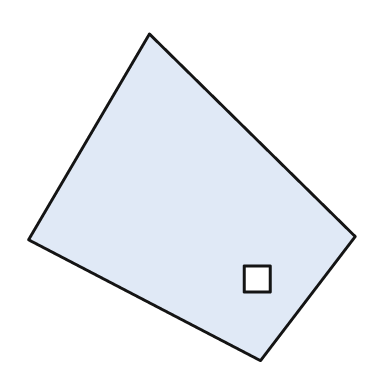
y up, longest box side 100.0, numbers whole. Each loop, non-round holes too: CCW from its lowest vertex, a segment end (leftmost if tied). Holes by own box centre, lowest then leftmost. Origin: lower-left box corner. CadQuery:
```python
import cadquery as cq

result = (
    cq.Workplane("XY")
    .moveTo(71.0, 0.0)
    .lineTo(100.0, 38.0)
    .lineTo(37.0, 100.0)
    .lineTo(0.0, 37.0)
    .close()
    .moveTo(66.0, 21.0)
    .lineTo(74.0, 21.0)
    .lineTo(74.0, 29.0)
    .lineTo(66.0, 29.0)
    .close()
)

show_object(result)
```